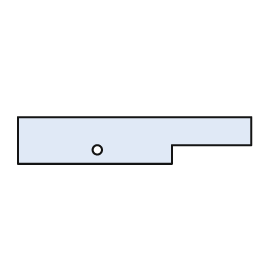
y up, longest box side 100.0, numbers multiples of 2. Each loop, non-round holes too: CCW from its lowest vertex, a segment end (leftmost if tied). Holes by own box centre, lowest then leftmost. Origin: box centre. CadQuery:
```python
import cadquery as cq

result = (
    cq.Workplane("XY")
    .moveTo(-50.0, -10.0)
    .lineTo(16.0, -10.0)
    .lineTo(16.0, -2.0)
    .lineTo(50.0, -2.0)
    .lineTo(50.0, 10.0)
    .lineTo(-50.0, 10.0)
    .close()
    .moveTo(-16.0, -4.0)
    .circle(2.0)
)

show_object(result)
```